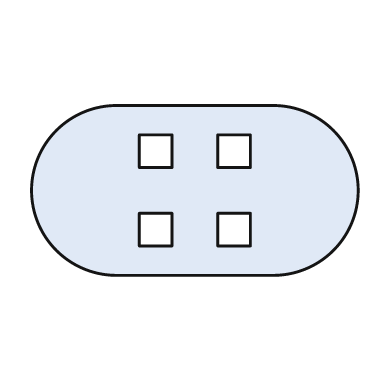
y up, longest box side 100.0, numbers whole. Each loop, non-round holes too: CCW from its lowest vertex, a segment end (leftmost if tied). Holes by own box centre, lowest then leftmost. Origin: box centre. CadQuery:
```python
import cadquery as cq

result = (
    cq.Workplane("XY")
    .moveTo(-24.0, -26.0)
    .lineTo(24.0, -26.0)
    .threePointArc((50.0, 0.0), (24.0, 26.0))
    .lineTo(-24.0, 26.0)
    .threePointArc((-50.0, 0.0), (-24.0, -26.0))
    .close()
    .moveTo(-17.0, -17.0)
    .lineTo(-7.0, -17.0)
    .lineTo(-7.0, -7.0)
    .lineTo(-17.0, -7.0)
    .close()
    .moveTo(7.0, -17.0)
    .lineTo(17.0, -17.0)
    .lineTo(17.0, -7.0)
    .lineTo(7.0, -7.0)
    .close()
    .moveTo(-17.0, 7.0)
    .lineTo(-7.0, 7.0)
    .lineTo(-7.0, 17.0)
    .lineTo(-17.0, 17.0)
    .close()
    .moveTo(7.0, 7.0)
    .lineTo(17.0, 7.0)
    .lineTo(17.0, 17.0)
    .lineTo(7.0, 17.0)
    .close()
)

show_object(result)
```